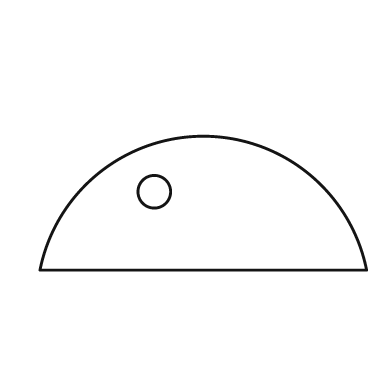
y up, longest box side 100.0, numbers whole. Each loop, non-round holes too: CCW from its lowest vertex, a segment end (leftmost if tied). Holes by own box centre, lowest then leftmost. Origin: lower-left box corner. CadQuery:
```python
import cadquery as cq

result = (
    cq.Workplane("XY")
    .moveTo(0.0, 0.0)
    .lineTo(100.0, 0.0)
    .threePointArc((50.0, 41.0), (0.0, 0.0))
    .close()
    .moveTo(35.0, 24.0)
    .circle(5.0)
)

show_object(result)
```